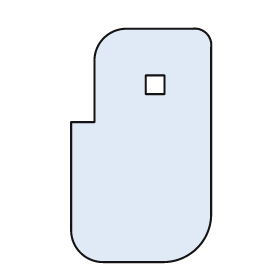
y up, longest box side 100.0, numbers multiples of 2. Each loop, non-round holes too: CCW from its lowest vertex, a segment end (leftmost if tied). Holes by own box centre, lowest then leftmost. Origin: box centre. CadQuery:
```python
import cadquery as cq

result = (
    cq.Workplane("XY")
    .moveTo(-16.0, -50.0)
    .lineTo(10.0, -50.0)
    .threePointArc((24.0, -44.0), (30.0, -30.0))
    .lineTo(30.0, 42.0)
    .threePointArc((28.0, 48.0), (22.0, 50.0))
    .lineTo(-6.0, 50.0)
    .threePointArc((-16.0, 46.0), (-20.0, 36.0))
    .lineTo(-20.0, 10.0)
    .lineTo(-30.0, 10.0)
    .lineTo(-30.0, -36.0)
    .threePointArc((-26.0, -46.0), (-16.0, -50.0))
    .close()
    .moveTo(2.0, 22.0)
    .lineTo(10.0, 22.0)
    .lineTo(10.0, 30.0)
    .lineTo(2.0, 30.0)
    .close()
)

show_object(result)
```